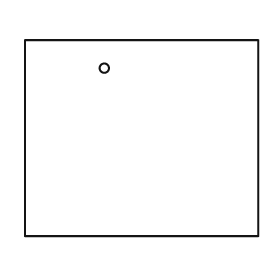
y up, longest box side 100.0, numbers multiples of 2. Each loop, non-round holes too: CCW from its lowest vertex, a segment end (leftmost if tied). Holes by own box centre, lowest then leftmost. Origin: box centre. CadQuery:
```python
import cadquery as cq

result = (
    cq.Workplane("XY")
    .moveTo(-50.0, -42.0)
    .lineTo(50.0, -42.0)
    .lineTo(50.0, 42.0)
    .lineTo(-50.0, 42.0)
    .close()
    .moveTo(-16.0, 30.0)
    .circle(2.0)
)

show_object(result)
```